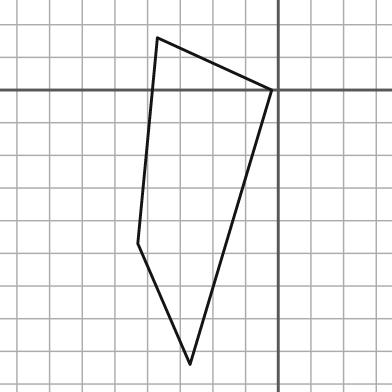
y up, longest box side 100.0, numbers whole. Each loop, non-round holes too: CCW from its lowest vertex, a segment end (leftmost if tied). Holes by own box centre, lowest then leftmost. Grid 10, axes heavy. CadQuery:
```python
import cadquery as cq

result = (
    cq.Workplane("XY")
    .moveTo(-27.0, -84.0)
    .lineTo(-2.0, 0.0)
    .lineTo(-37.0, 16.0)
    .lineTo(-43.0, -47.0)
    .close()
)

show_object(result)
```